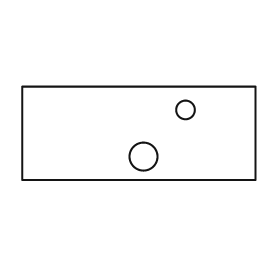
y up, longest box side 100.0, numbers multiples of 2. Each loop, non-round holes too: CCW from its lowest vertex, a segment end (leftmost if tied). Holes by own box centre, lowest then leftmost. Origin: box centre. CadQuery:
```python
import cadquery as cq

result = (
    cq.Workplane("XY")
    .moveTo(-50.0, -20.0)
    .lineTo(50.0, -20.0)
    .lineTo(50.0, 20.0)
    .lineTo(-50.0, 20.0)
    .close()
    .moveTo(2.0, -10.0)
    .circle(6.0)
    .moveTo(20.0, 10.0)
    .circle(4.0)
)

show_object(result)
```